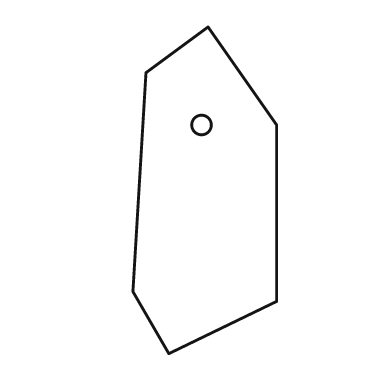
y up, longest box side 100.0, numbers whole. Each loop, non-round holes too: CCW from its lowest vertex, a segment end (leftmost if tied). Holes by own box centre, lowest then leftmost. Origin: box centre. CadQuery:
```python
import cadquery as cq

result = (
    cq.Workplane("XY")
    .moveTo(-11.0, -50.0)
    .lineTo(22.0, -34.0)
    .lineTo(22.0, 20.0)
    .lineTo(1.0, 50.0)
    .lineTo(-18.0, 36.0)
    .lineTo(-22.0, -31.0)
    .close()
    .moveTo(-1.0, 20.0)
    .circle(3.0)
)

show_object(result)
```